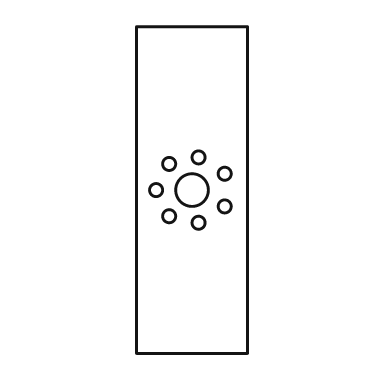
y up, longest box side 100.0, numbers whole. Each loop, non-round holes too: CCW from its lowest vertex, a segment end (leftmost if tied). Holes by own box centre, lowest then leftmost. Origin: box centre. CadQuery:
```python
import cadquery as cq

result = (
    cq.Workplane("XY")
    .moveTo(-17.0, -50.0)
    .lineTo(17.0, -50.0)
    .lineTo(17.0, 50.0)
    .lineTo(-17.0, 50.0)
    .close()
    .moveTo(2.0, -10.0)
    .circle(2.0)
    .moveTo(-7.0, -8.0)
    .circle(2.0)
    .moveTo(10.0, -5.0)
    .circle(2.0)
    .moveTo(-11.0, 0.0)
    .circle(2.0)
    .moveTo(0.0, 0.0)
    .circle(5.0)
    .moveTo(10.0, 5.0)
    .circle(2.0)
    .moveTo(-7.0, 8.0)
    .circle(2.0)
    .moveTo(2.0, 10.0)
    .circle(2.0)
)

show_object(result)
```